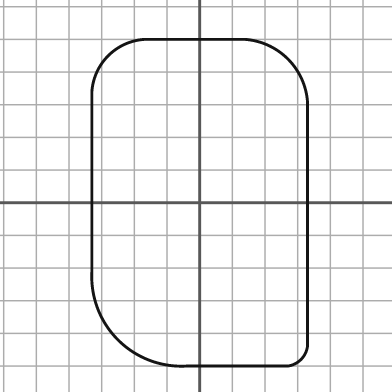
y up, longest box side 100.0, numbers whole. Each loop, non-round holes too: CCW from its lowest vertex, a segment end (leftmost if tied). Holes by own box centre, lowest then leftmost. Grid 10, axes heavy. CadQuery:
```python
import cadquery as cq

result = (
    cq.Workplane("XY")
    .moveTo(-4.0, -50.0)
    .lineTo(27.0, -50.0)
    .threePointArc((31.0, -48.0), (33.0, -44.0))
    .lineTo(33.0, 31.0)
    .threePointArc((27.0, 44.0), (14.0, 50.0))
    .lineTo(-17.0, 50.0)
    .threePointArc((-28.0, 45.0), (-33.0, 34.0))
    .lineTo(-33.0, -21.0)
    .threePointArc((-25.0, -42.0), (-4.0, -50.0))
    .close()
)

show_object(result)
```